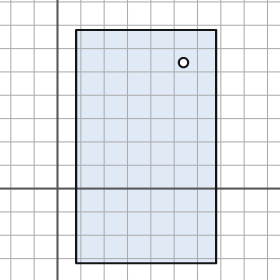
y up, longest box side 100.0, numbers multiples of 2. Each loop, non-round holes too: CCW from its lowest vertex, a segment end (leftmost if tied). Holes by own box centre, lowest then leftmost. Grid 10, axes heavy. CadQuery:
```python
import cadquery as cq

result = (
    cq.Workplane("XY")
    .moveTo(8.0, -32.0)
    .lineTo(68.0, -32.0)
    .lineTo(68.0, 68.0)
    .lineTo(8.0, 68.0)
    .close()
    .moveTo(54.0, 54.0)
    .circle(2.0)
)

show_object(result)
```